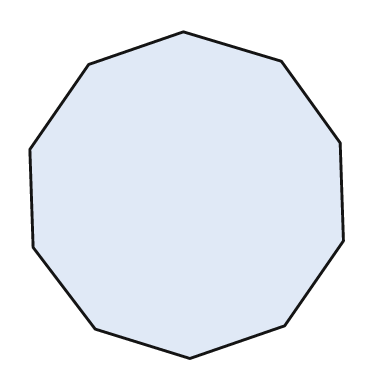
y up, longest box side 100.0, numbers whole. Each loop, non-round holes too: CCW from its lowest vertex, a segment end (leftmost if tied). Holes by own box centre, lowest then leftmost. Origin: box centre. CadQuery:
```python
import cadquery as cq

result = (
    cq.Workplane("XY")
    .moveTo(1.0, -50.0)
    .lineTo(30.0, -40.0)
    .lineTo(48.0, -14.0)
    .lineTo(47.0, 16.0)
    .lineTo(29.0, 41.0)
    .lineTo(-1.0, 50.0)
    .lineTo(-30.0, 40.0)
    .lineTo(-48.0, 14.0)
    .lineTo(-47.0, -16.0)
    .lineTo(-28.0, -41.0)
    .close()
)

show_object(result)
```